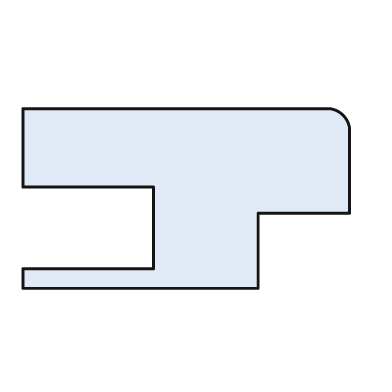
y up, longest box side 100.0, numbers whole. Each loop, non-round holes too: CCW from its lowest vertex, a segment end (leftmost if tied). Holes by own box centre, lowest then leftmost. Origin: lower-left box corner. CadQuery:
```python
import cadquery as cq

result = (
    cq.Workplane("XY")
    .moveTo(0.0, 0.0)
    .lineTo(72.0, 0.0)
    .lineTo(72.0, 23.0)
    .lineTo(100.0, 23.0)
    .lineTo(100.0, 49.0)
    .threePointArc((98.0, 53.0), (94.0, 55.0))
    .lineTo(0.0, 55.0)
    .lineTo(0.0, 31.0)
    .lineTo(40.0, 31.0)
    .lineTo(40.0, 6.0)
    .lineTo(0.0, 6.0)
    .close()
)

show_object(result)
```